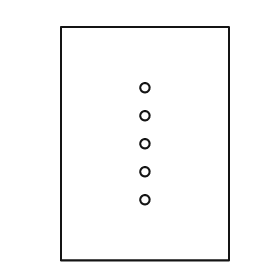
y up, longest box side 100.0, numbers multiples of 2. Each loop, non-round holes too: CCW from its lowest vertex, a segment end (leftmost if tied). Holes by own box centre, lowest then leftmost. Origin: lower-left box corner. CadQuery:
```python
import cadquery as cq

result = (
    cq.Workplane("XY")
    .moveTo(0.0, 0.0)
    .lineTo(72.0, 0.0)
    .lineTo(72.0, 100.0)
    .lineTo(0.0, 100.0)
    .close()
    .moveTo(36.0, 26.0)
    .circle(2.0)
    .moveTo(36.0, 38.0)
    .circle(2.0)
    .moveTo(36.0, 50.0)
    .circle(2.0)
    .moveTo(36.0, 62.0)
    .circle(2.0)
    .moveTo(36.0, 74.0)
    .circle(2.0)
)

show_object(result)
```